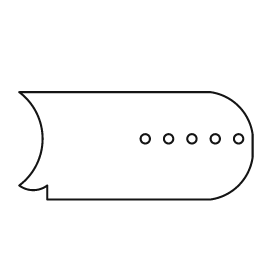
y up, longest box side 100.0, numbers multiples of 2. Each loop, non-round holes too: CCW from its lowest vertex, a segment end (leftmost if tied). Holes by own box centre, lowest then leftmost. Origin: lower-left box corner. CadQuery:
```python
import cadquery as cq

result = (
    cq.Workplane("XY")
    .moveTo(12.0, 0.0)
    .lineTo(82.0, 0.0)
    .threePointArc((94.0, 6.0), (100.0, 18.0))
    .lineTo(100.0, 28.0)
    .threePointArc((94.0, 40.0), (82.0, 46.0))
    .lineTo(0.0, 46.0)
    .threePointArc((10.0, 26.0), (0.0, 6.0))
    .threePointArc((6.0, 4.0), (12.0, 6.0))
    .close()
    .moveTo(54.0, 26.0)
    .circle(2.0)
    .moveTo(64.0, 26.0)
    .circle(2.0)
    .moveTo(74.0, 26.0)
    .circle(2.0)
    .moveTo(84.0, 26.0)
    .circle(2.0)
    .moveTo(94.0, 26.0)
    .circle(2.0)
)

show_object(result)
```